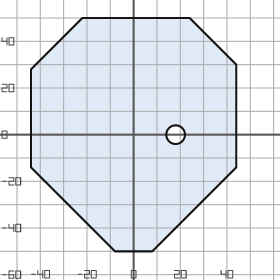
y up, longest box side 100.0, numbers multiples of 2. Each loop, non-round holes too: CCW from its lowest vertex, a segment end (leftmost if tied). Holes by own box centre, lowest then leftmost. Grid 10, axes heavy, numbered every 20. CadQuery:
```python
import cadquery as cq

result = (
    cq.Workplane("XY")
    .moveTo(-8.0, -50.0)
    .lineTo(8.0, -50.0)
    .lineTo(44.0, -14.0)
    .lineTo(44.0, 30.0)
    .lineTo(24.0, 50.0)
    .lineTo(-22.0, 50.0)
    .lineTo(-44.0, 28.0)
    .lineTo(-44.0, -14.0)
    .close()
    .moveTo(18.0, 0.0)
    .circle(4.0)
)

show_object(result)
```